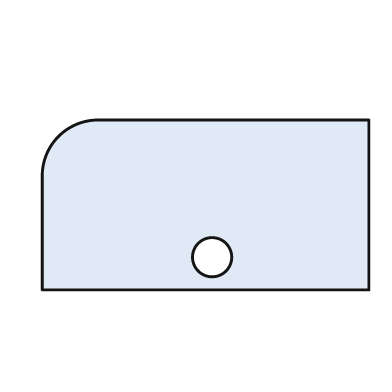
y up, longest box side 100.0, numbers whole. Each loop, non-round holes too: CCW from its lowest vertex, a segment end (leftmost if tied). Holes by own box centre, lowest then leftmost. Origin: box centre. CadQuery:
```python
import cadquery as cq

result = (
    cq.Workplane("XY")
    .moveTo(-50.0, -26.0)
    .lineTo(50.0, -26.0)
    .lineTo(50.0, 26.0)
    .lineTo(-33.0, 26.0)
    .threePointArc((-45.0, 21.0), (-50.0, 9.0))
    .close()
    .moveTo(2.0, -16.0)
    .circle(6.0)
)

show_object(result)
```